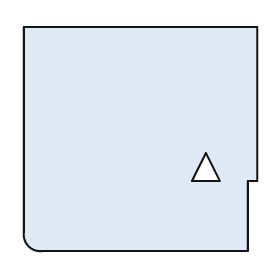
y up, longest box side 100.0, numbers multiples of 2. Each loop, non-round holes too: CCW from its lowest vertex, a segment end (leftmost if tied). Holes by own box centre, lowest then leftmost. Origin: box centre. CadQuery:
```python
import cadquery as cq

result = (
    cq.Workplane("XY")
    .moveTo(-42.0, -48.0)
    .lineTo(46.0, -48.0)
    .lineTo(46.0, -18.0)
    .lineTo(50.0, -18.0)
    .lineTo(50.0, 48.0)
    .lineTo(-50.0, 48.0)
    .lineTo(-50.0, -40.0)
    .threePointArc((-48.0, -46.0), (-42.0, -48.0))
    .close()
    .moveTo(22.0, -18.0)
    .lineTo(34.0, -18.0)
    .lineTo(28.0, -6.0)
    .close()
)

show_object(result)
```